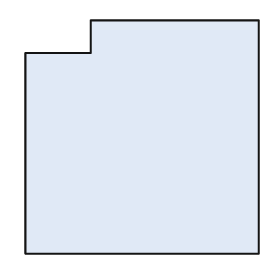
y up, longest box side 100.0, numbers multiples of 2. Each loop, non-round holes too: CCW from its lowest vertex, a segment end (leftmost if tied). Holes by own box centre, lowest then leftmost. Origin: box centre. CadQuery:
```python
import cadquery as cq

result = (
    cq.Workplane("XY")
    .moveTo(-50.0, -50.0)
    .lineTo(50.0, -50.0)
    .lineTo(50.0, 50.0)
    .lineTo(-22.0, 50.0)
    .lineTo(-22.0, 36.0)
    .lineTo(-50.0, 36.0)
    .close()
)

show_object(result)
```